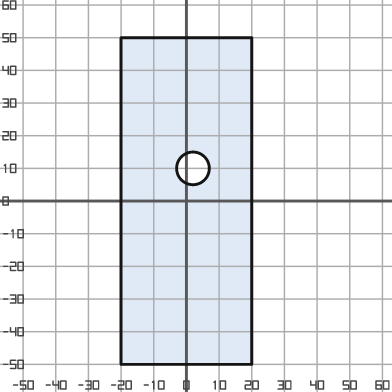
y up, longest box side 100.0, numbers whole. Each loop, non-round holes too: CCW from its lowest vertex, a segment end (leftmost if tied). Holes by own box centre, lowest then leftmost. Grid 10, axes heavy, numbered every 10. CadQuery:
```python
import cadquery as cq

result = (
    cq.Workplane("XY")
    .moveTo(-20.0, -50.0)
    .lineTo(20.0, -50.0)
    .lineTo(20.0, 50.0)
    .lineTo(-20.0, 50.0)
    .close()
    .moveTo(2.0, 10.0)
    .circle(5.0)
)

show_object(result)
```